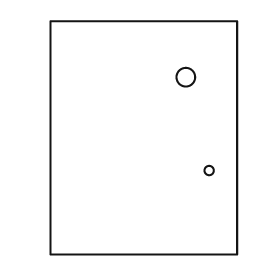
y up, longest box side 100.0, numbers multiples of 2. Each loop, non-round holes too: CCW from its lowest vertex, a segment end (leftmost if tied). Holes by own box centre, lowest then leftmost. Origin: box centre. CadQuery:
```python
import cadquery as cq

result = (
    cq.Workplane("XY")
    .moveTo(-40.0, -50.0)
    .lineTo(40.0, -50.0)
    .lineTo(40.0, 50.0)
    .lineTo(-40.0, 50.0)
    .close()
    .moveTo(28.0, -14.0)
    .circle(2.0)
    .moveTo(18.0, 26.0)
    .circle(4.0)
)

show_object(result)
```